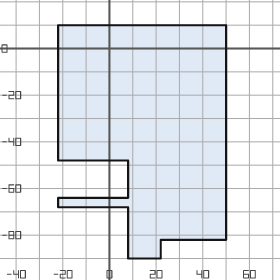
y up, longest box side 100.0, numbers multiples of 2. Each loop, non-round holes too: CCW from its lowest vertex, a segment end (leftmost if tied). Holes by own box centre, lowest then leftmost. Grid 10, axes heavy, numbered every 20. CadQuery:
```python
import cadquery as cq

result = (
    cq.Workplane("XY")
    .moveTo(8.0, -90.0)
    .lineTo(22.0, -90.0)
    .lineTo(22.0, -82.0)
    .lineTo(50.0, -82.0)
    .lineTo(50.0, 10.0)
    .lineTo(-22.0, 10.0)
    .lineTo(-22.0, -48.0)
    .lineTo(8.0, -48.0)
    .lineTo(8.0, -64.0)
    .lineTo(-22.0, -64.0)
    .lineTo(-22.0, -68.0)
    .lineTo(8.0, -68.0)
    .close()
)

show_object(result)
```